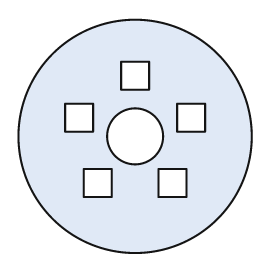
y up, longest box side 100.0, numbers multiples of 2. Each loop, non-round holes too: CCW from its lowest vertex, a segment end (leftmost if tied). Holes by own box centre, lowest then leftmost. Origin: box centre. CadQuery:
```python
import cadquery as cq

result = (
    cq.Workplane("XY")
    .moveTo(0.0, 0.0)
    .circle(50.0)
    .moveTo(-22.0, -26.0)
    .lineTo(-10.0, -26.0)
    .lineTo(-10.0, -14.0)
    .lineTo(-22.0, -14.0)
    .close()
    .moveTo(10.0, -26.0)
    .lineTo(22.0, -26.0)
    .lineTo(22.0, -14.0)
    .lineTo(10.0, -14.0)
    .close()
    .moveTo(0.0, 0.0)
    .circle(12.0)
    .moveTo(-30.0, 2.0)
    .lineTo(-18.0, 2.0)
    .lineTo(-18.0, 14.0)
    .lineTo(-30.0, 14.0)
    .close()
    .moveTo(18.0, 2.0)
    .lineTo(30.0, 2.0)
    .lineTo(30.0, 14.0)
    .lineTo(18.0, 14.0)
    .close()
    .moveTo(-6.0, 20.0)
    .lineTo(6.0, 20.0)
    .lineTo(6.0, 32.0)
    .lineTo(-6.0, 32.0)
    .close()
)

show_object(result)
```